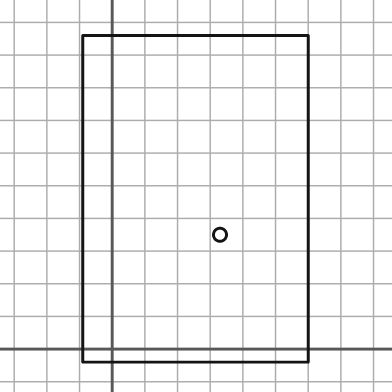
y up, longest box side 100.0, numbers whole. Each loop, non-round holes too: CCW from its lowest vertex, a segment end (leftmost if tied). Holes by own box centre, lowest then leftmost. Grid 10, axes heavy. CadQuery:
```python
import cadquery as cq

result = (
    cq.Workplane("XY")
    .moveTo(-9.0, -4.0)
    .lineTo(60.0, -4.0)
    .lineTo(60.0, 96.0)
    .lineTo(-9.0, 96.0)
    .close()
    .moveTo(33.0, 35.0)
    .circle(2.0)
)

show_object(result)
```